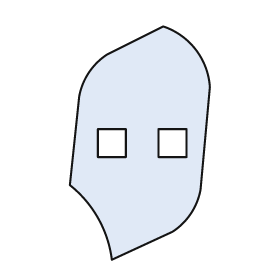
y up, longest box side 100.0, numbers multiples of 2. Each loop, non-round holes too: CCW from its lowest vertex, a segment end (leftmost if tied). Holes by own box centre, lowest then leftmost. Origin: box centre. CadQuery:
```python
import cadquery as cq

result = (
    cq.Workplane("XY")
    .moveTo(-12.0, -50.0)
    .lineTo(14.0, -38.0)
    .threePointArc((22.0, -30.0), (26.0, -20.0))
    .lineTo(30.0, 24.0)
    .threePointArc((24.0, 40.0), (10.0, 50.0))
    .lineTo(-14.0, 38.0)
    .threePointArc((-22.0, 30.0), (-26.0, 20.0))
    .lineTo(-30.0, -18.0)
    .threePointArc((-18.0, -32.0), (-12.0, -50.0))
    .close()
    .moveTo(-18.0, -6.0)
    .lineTo(-6.0, -6.0)
    .lineTo(-6.0, 6.0)
    .lineTo(-18.0, 6.0)
    .close()
    .moveTo(8.0, -6.0)
    .lineTo(20.0, -6.0)
    .lineTo(20.0, 6.0)
    .lineTo(8.0, 6.0)
    .close()
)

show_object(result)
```